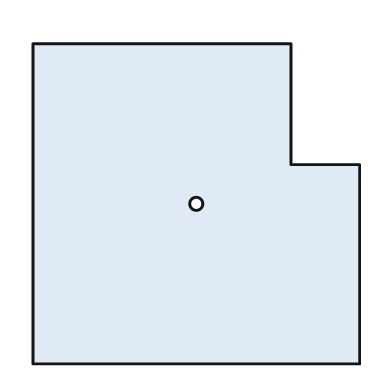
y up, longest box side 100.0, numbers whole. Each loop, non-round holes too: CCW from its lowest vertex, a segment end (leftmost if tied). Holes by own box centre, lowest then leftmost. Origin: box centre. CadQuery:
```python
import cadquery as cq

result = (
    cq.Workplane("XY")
    .moveTo(-50.0, -49.0)
    .lineTo(50.0, -49.0)
    .lineTo(50.0, 12.0)
    .lineTo(29.0, 12.0)
    .lineTo(29.0, 49.0)
    .lineTo(-50.0, 49.0)
    .close()
    .moveTo(0.0, 0.0)
    .circle(2.0)
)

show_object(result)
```